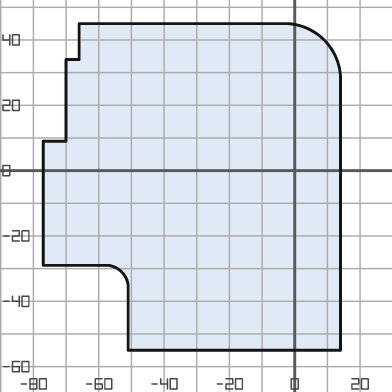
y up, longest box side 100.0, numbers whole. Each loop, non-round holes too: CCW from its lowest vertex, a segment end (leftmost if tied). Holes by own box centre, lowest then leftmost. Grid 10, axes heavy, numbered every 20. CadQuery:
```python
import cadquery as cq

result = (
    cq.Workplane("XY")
    .moveTo(-51.0, -55.0)
    .lineTo(14.0, -55.0)
    .lineTo(14.0, 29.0)
    .threePointArc((9.0, 40.0), (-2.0, 45.0))
    .lineTo(-66.0, 45.0)
    .lineTo(-66.0, 34.0)
    .lineTo(-70.0, 34.0)
    .lineTo(-70.0, 9.0)
    .lineTo(-77.0, 9.0)
    .lineTo(-77.0, -29.0)
    .lineTo(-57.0, -29.0)
    .threePointArc((-53.0, -31.0), (-51.0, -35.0))
    .close()
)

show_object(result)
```